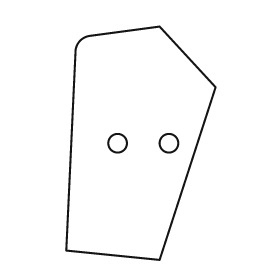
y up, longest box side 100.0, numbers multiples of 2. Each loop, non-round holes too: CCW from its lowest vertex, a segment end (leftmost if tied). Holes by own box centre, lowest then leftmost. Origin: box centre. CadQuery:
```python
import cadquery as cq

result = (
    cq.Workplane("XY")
    .moveTo(8.0, -50.0)
    .lineTo(32.0, 24.0)
    .lineTo(8.0, 50.0)
    .lineTo(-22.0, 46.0)
    .threePointArc((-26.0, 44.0), (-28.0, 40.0))
    .lineTo(-32.0, -46.0)
    .close()
    .moveTo(-10.0, 0.0)
    .circle(4.0)
    .moveTo(12.0, 0.0)
    .circle(4.0)
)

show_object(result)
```